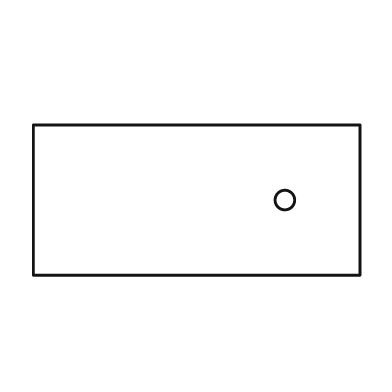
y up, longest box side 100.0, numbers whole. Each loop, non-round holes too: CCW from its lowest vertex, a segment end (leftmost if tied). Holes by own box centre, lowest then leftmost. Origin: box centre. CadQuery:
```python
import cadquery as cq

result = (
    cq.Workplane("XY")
    .moveTo(-50.0, -23.0)
    .lineTo(50.0, -23.0)
    .lineTo(50.0, 23.0)
    .lineTo(-50.0, 23.0)
    .close()
    .moveTo(27.0, 0.0)
    .circle(3.0)
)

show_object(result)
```